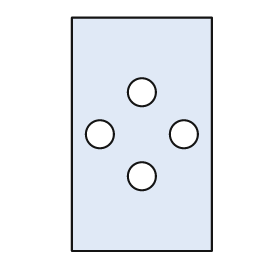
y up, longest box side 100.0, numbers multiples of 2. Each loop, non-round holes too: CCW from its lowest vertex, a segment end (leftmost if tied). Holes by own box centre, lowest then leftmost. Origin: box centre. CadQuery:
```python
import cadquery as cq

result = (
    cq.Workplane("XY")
    .moveTo(-30.0, -50.0)
    .lineTo(30.0, -50.0)
    .lineTo(30.0, 50.0)
    .lineTo(-30.0, 50.0)
    .close()
    .moveTo(0.0, -18.0)
    .circle(6.0)
    .moveTo(-18.0, 0.0)
    .circle(6.0)
    .moveTo(18.0, 0.0)
    .circle(6.0)
    .moveTo(0.0, 18.0)
    .circle(6.0)
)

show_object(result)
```